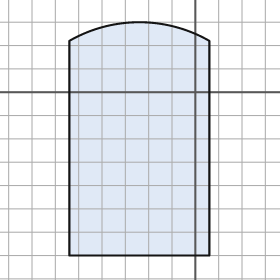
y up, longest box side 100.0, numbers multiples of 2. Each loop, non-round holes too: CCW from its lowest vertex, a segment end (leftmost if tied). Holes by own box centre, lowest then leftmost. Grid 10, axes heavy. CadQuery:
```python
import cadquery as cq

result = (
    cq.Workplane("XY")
    .moveTo(-54.0, -70.0)
    .lineTo(6.0, -70.0)
    .lineTo(6.0, 22.0)
    .threePointArc((-24.0, 30.0), (-54.0, 22.0))
    .close()
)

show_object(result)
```